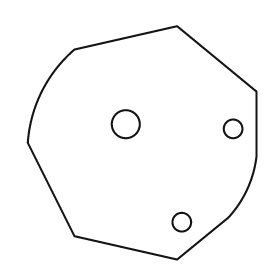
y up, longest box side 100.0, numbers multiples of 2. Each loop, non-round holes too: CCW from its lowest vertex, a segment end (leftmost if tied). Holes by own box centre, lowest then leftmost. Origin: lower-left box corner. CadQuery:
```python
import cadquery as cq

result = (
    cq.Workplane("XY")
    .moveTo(64.0, 0.0)
    .lineTo(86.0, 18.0)
    .threePointArc((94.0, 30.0), (98.0, 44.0))
    .lineTo(98.0, 72.0)
    .lineTo(64.0, 100.0)
    .lineTo(20.0, 90.0)
    .threePointArc((6.0, 72.0), (0.0, 50.0))
    .lineTo(20.0, 10.0)
    .close()
    .moveTo(66.0, 16.0)
    .circle(4.0)
    .moveTo(88.0, 56.0)
    .circle(4.0)
    .moveTo(42.0, 58.0)
    .circle(6.0)
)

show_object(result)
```